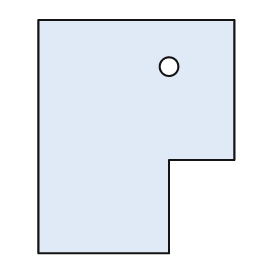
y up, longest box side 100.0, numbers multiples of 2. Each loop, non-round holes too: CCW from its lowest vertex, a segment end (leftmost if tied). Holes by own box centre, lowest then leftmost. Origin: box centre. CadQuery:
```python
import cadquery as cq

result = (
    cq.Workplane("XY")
    .moveTo(-42.0, -50.0)
    .lineTo(14.0, -50.0)
    .lineTo(14.0, -10.0)
    .lineTo(42.0, -10.0)
    .lineTo(42.0, 50.0)
    .lineTo(-42.0, 50.0)
    .close()
    .moveTo(14.0, 30.0)
    .circle(4.0)
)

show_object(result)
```